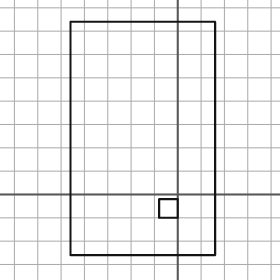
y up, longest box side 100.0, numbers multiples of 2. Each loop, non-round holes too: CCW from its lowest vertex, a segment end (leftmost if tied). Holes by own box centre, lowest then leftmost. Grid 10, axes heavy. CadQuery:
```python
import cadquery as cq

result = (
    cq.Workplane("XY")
    .moveTo(-46.0, -26.0)
    .lineTo(16.0, -26.0)
    .lineTo(16.0, 74.0)
    .lineTo(-46.0, 74.0)
    .close()
    .moveTo(-8.0, -10.0)
    .lineTo(0.0, -10.0)
    .lineTo(0.0, -2.0)
    .lineTo(-8.0, -2.0)
    .close()
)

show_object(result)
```